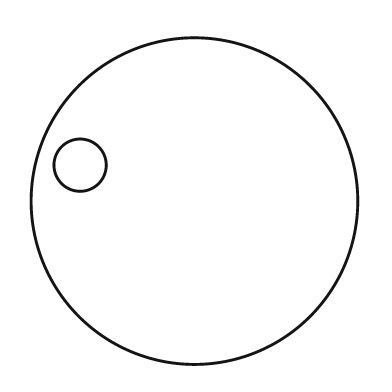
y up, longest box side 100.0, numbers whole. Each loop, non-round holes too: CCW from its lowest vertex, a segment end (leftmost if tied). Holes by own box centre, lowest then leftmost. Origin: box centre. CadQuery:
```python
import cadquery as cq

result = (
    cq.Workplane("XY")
    .moveTo(0.0, 0.0)
    .circle(50.0)
    .moveTo(-35.0, 11.0)
    .circle(8.0)
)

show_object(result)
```